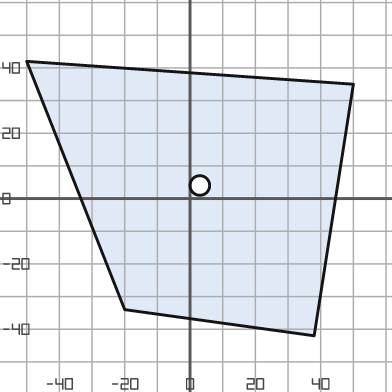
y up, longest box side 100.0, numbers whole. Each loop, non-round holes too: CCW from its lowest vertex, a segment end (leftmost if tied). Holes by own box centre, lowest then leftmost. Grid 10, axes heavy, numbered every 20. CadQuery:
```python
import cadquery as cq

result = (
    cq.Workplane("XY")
    .moveTo(38.0, -42.0)
    .lineTo(50.0, 35.0)
    .lineTo(-50.0, 42.0)
    .lineTo(-20.0, -34.0)
    .close()
    .moveTo(3.0, 4.0)
    .circle(3.0)
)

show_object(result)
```